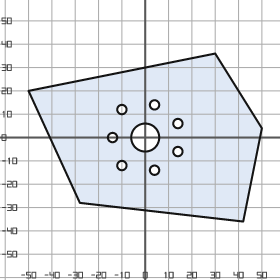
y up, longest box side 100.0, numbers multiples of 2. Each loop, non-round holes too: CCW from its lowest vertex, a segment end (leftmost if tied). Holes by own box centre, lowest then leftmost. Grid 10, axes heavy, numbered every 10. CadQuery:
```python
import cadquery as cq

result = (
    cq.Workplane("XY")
    .moveTo(42.0, -36.0)
    .lineTo(50.0, 4.0)
    .lineTo(30.0, 36.0)
    .lineTo(-50.0, 20.0)
    .lineTo(-28.0, -28.0)
    .close()
    .moveTo(4.0, -14.0)
    .circle(2.0)
    .moveTo(-10.0, -12.0)
    .circle(2.0)
    .moveTo(14.0, -6.0)
    .circle(2.0)
    .moveTo(-14.0, 0.0)
    .circle(2.0)
    .moveTo(0.0, 0.0)
    .circle(6.0)
    .moveTo(14.0, 6.0)
    .circle(2.0)
    .moveTo(-10.0, 12.0)
    .circle(2.0)
    .moveTo(4.0, 14.0)
    .circle(2.0)
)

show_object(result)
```